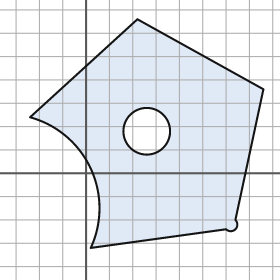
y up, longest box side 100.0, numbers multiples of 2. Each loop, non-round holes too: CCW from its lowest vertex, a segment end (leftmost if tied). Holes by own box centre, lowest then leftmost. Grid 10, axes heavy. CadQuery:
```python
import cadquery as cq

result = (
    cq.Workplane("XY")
    .moveTo(2.0, -32.0)
    .lineTo(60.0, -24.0)
    .threePointArc((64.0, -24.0), (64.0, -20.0))
    .lineTo(76.0, 36.0)
    .lineTo(22.0, 66.0)
    .lineTo(-24.0, 24.0)
    .threePointArc((2.0, 2.0), (2.0, -32.0))
    .close()
    .moveTo(26.0, 18.0)
    .circle(10.0)
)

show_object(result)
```